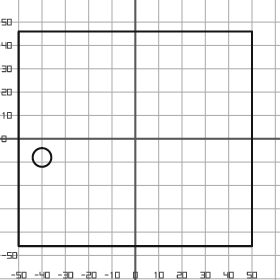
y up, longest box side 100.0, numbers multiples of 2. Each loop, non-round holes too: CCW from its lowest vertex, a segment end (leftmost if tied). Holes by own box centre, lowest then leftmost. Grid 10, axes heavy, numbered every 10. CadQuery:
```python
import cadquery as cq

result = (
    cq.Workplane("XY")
    .moveTo(-50.0, -46.0)
    .lineTo(50.0, -46.0)
    .lineTo(50.0, 46.0)
    .lineTo(-50.0, 46.0)
    .close()
    .moveTo(-40.0, -8.0)
    .circle(4.0)
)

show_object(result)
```